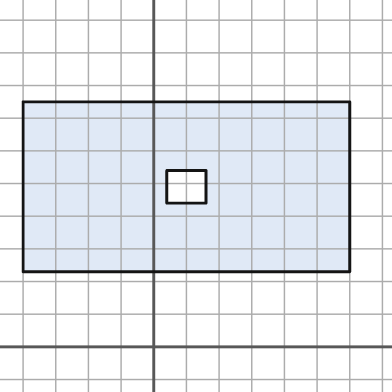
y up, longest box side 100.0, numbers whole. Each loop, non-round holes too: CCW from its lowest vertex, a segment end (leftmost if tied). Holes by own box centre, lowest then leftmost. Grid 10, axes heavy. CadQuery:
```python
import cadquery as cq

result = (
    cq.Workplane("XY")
    .moveTo(-40.0, 23.0)
    .lineTo(60.0, 23.0)
    .lineTo(60.0, 75.0)
    .lineTo(-40.0, 75.0)
    .close()
    .moveTo(4.0, 44.0)
    .lineTo(16.0, 44.0)
    .lineTo(16.0, 54.0)
    .lineTo(4.0, 54.0)
    .close()
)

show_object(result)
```